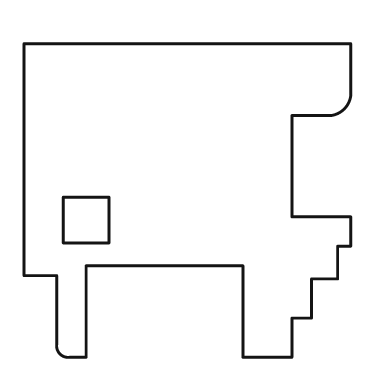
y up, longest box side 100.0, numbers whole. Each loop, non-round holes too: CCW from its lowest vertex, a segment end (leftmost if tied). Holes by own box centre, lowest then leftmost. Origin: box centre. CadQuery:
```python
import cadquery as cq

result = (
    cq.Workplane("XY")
    .moveTo(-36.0, -48.0)
    .lineTo(-31.0, -48.0)
    .lineTo(-31.0, -20.0)
    .lineTo(17.0, -20.0)
    .lineTo(17.0, -48.0)
    .lineTo(32.0, -48.0)
    .lineTo(32.0, -36.0)
    .lineTo(38.0, -36.0)
    .lineTo(38.0, -24.0)
    .lineTo(46.0, -24.0)
    .lineTo(46.0, -14.0)
    .lineTo(50.0, -14.0)
    .lineTo(50.0, -5.0)
    .lineTo(32.0, -5.0)
    .lineTo(32.0, 26.0)
    .lineTo(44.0, 26.0)
    .threePointArc((48.0, 28.0), (50.0, 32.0))
    .lineTo(50.0, 48.0)
    .lineTo(-50.0, 48.0)
    .lineTo(-50.0, -23.0)
    .lineTo(-40.0, -23.0)
    .lineTo(-40.0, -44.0)
    .threePointArc((-39.0, -47.0), (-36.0, -48.0))
    .close()
    .moveTo(-38.0, -13.0)
    .lineTo(-24.0, -13.0)
    .lineTo(-24.0, 1.0)
    .lineTo(-38.0, 1.0)
    .close()
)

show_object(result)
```